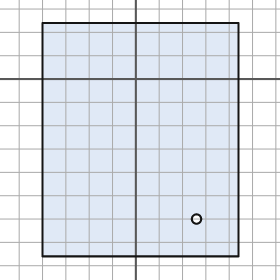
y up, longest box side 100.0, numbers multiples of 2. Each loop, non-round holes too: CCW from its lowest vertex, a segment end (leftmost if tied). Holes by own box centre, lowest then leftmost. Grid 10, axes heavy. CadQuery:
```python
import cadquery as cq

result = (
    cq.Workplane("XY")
    .moveTo(-40.0, -76.0)
    .lineTo(44.0, -76.0)
    .lineTo(44.0, 24.0)
    .lineTo(-40.0, 24.0)
    .close()
    .moveTo(26.0, -60.0)
    .circle(2.0)
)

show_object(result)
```